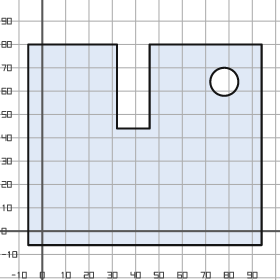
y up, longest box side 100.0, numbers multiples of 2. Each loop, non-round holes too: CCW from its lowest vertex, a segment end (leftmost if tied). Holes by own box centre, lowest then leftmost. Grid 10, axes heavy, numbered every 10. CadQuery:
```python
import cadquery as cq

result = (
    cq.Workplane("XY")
    .moveTo(-6.0, -6.0)
    .lineTo(94.0, -6.0)
    .lineTo(94.0, 80.0)
    .lineTo(46.0, 80.0)
    .lineTo(46.0, 44.0)
    .lineTo(32.0, 44.0)
    .lineTo(32.0, 80.0)
    .lineTo(-6.0, 80.0)
    .close()
    .moveTo(78.0, 64.0)
    .circle(6.0)
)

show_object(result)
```